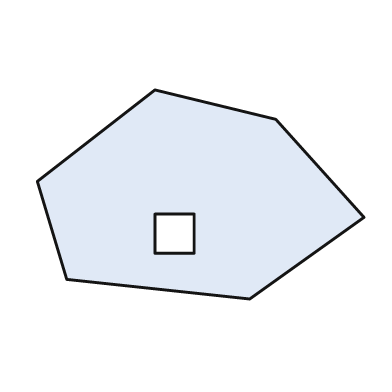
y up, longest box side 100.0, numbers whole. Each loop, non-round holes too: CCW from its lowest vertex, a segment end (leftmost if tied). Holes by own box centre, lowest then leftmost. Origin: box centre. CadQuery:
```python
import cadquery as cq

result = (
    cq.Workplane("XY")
    .moveTo(15.0, -32.0)
    .lineTo(50.0, -7.0)
    .lineTo(23.0, 23.0)
    .lineTo(-14.0, 32.0)
    .lineTo(-50.0, 4.0)
    .lineTo(-41.0, -26.0)
    .close()
    .moveTo(-14.0, -18.0)
    .lineTo(-2.0, -18.0)
    .lineTo(-2.0, -6.0)
    .lineTo(-14.0, -6.0)
    .close()
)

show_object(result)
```